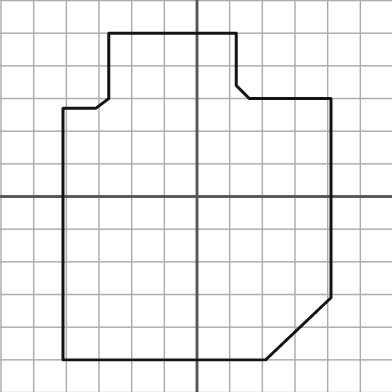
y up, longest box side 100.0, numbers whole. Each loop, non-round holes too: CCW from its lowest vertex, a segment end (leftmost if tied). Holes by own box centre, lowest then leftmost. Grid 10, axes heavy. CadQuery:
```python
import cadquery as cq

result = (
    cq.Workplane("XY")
    .moveTo(-41.0, -50.0)
    .lineTo(21.0, -50.0)
    .lineTo(41.0, -31.0)
    .lineTo(41.0, 30.0)
    .lineTo(16.0, 30.0)
    .lineTo(12.0, 34.0)
    .lineTo(12.0, 50.0)
    .lineTo(-27.0, 50.0)
    .lineTo(-27.0, 30.0)
    .lineTo(-31.0, 27.0)
    .lineTo(-41.0, 27.0)
    .close()
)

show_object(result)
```